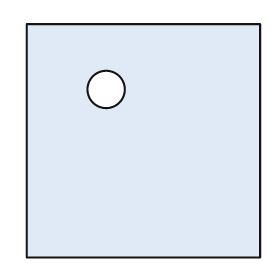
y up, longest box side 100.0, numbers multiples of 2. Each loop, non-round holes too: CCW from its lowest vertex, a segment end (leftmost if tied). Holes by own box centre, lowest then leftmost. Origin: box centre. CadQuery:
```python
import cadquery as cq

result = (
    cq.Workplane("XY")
    .moveTo(-50.0, -50.0)
    .lineTo(50.0, -50.0)
    .lineTo(50.0, 50.0)
    .lineTo(-50.0, 50.0)
    .close()
    .moveTo(-16.0, 22.0)
    .circle(8.0)
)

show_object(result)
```